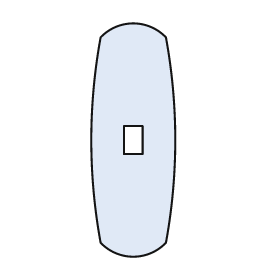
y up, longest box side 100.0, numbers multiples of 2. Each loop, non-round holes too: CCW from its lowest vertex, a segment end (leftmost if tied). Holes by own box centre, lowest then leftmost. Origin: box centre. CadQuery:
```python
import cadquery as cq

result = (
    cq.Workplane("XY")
    .moveTo(-14.0, -44.0)
    .threePointArc((0.0, -50.0), (14.0, -44.0))
    .threePointArc((18.0, 0.0), (14.0, 44.0))
    .threePointArc((0.0, 50.0), (-14.0, 44.0))
    .threePointArc((-18.0, 0.0), (-14.0, -44.0))
    .close()
    .moveTo(-4.0, -6.0)
    .lineTo(4.0, -6.0)
    .lineTo(4.0, 6.0)
    .lineTo(-4.0, 6.0)
    .close()
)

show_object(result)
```